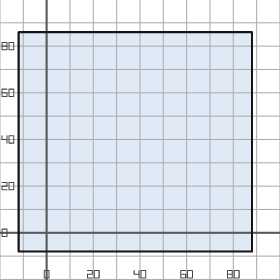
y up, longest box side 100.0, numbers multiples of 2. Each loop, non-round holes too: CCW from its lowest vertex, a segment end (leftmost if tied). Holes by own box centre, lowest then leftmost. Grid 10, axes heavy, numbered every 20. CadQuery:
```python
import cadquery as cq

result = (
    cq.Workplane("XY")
    .moveTo(-12.0, -8.0)
    .lineTo(88.0, -8.0)
    .lineTo(88.0, 86.0)
    .lineTo(-12.0, 86.0)
    .close()
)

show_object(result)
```